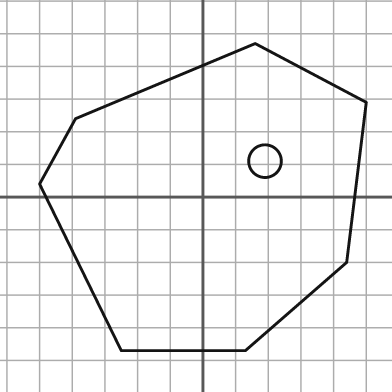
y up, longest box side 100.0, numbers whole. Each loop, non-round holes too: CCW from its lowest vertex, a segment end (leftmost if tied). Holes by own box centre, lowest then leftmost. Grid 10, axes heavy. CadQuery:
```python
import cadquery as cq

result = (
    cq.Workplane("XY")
    .moveTo(-25.0, -47.0)
    .lineTo(13.0, -47.0)
    .lineTo(44.0, -20.0)
    .lineTo(50.0, 29.0)
    .lineTo(16.0, 47.0)
    .lineTo(-39.0, 24.0)
    .lineTo(-50.0, 4.0)
    .close()
    .moveTo(19.0, 11.0)
    .circle(5.0)
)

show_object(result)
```